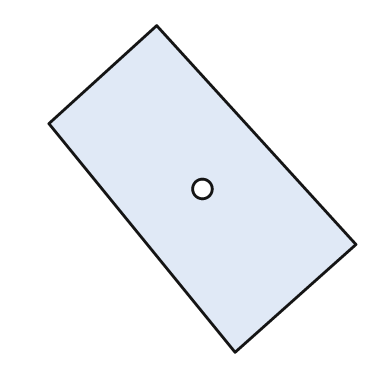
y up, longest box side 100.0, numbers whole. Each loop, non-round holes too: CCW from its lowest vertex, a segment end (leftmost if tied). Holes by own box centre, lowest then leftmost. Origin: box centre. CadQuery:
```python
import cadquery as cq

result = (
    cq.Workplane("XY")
    .moveTo(10.0, -50.0)
    .lineTo(47.0, -17.0)
    .lineTo(-14.0, 50.0)
    .lineTo(-47.0, 20.0)
    .close()
    .moveTo(0.0, 0.0)
    .circle(3.0)
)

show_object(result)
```